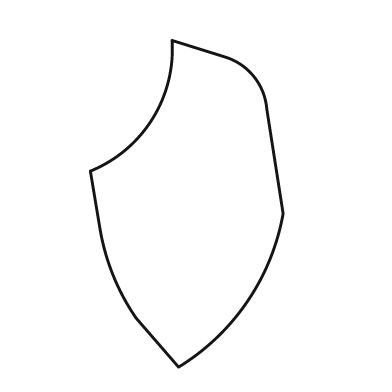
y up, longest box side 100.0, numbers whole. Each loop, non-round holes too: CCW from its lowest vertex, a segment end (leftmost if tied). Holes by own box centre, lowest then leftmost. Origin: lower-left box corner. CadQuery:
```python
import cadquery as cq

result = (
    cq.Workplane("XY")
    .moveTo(27.0, 0.0)
    .threePointArc((48.0, 20.0), (59.0, 47.0))
    .lineTo(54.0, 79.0)
    .threePointArc((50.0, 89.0), (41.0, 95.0))
    .lineTo(25.0, 100.0)
    .threePointArc((19.0, 76.0), (0.0, 60.0))
    .lineTo(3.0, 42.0)
    .threePointArc((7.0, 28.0), (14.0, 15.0))
    .close()
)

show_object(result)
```